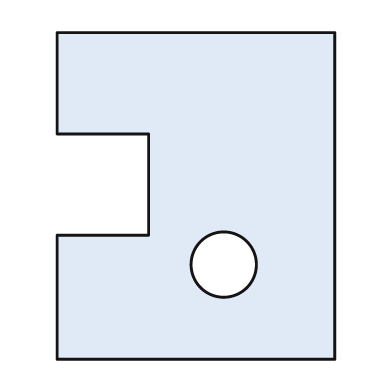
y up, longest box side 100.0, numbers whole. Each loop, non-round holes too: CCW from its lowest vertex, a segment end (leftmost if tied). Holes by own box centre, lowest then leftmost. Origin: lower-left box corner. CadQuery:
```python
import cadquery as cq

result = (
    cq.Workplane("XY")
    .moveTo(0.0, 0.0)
    .lineTo(85.0, 0.0)
    .lineTo(85.0, 100.0)
    .lineTo(0.0, 100.0)
    .lineTo(0.0, 69.0)
    .lineTo(28.0, 69.0)
    .lineTo(28.0, 38.0)
    .lineTo(0.0, 38.0)
    .close()
    .moveTo(51.0, 29.0)
    .circle(10.0)
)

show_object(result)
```